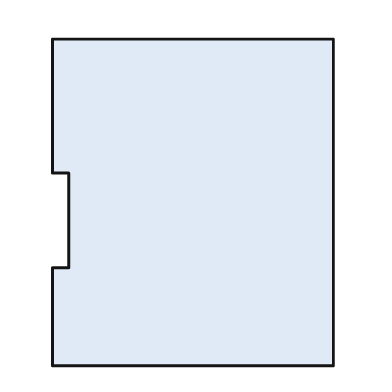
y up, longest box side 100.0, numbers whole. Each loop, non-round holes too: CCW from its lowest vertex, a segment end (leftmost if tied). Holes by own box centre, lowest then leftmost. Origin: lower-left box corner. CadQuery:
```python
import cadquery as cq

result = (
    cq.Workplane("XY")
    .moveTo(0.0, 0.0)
    .lineTo(86.0, 0.0)
    .lineTo(86.0, 100.0)
    .lineTo(0.0, 100.0)
    .lineTo(0.0, 59.0)
    .lineTo(5.0, 59.0)
    .lineTo(5.0, 30.0)
    .lineTo(0.0, 30.0)
    .close()
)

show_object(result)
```